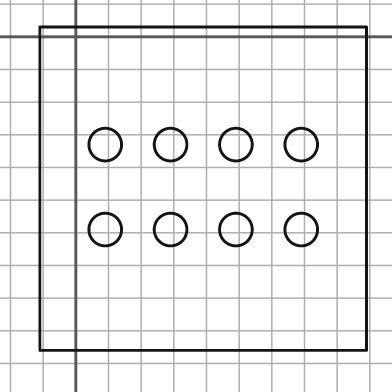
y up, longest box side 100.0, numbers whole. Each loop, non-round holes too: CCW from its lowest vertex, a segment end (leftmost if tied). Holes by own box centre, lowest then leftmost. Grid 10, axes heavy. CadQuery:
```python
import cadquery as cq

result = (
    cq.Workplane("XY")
    .moveTo(-11.0, -96.0)
    .lineTo(89.0, -96.0)
    .lineTo(89.0, 3.0)
    .lineTo(-11.0, 3.0)
    .close()
    .moveTo(9.0, -59.0)
    .circle(5.0)
    .moveTo(29.0, -59.0)
    .circle(5.0)
    .moveTo(49.0, -59.0)
    .circle(5.0)
    .moveTo(69.0, -59.0)
    .circle(5.0)
    .moveTo(9.0, -33.0)
    .circle(5.0)
    .moveTo(29.0, -33.0)
    .circle(5.0)
    .moveTo(49.0, -33.0)
    .circle(5.0)
    .moveTo(69.0, -33.0)
    .circle(5.0)
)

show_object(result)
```